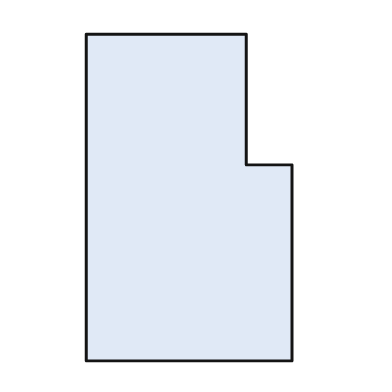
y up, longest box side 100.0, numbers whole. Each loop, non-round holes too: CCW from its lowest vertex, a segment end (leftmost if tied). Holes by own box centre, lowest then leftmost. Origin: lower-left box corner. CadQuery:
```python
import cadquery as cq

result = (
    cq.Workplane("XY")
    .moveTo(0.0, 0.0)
    .lineTo(63.0, 0.0)
    .lineTo(63.0, 60.0)
    .lineTo(49.0, 60.0)
    .lineTo(49.0, 100.0)
    .lineTo(0.0, 100.0)
    .close()
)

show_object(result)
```